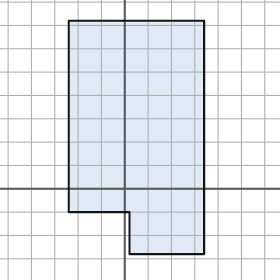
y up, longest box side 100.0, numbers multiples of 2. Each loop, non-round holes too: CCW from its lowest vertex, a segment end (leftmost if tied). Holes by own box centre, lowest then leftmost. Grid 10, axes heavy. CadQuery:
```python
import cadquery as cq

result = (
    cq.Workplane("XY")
    .moveTo(2.0, -28.0)
    .lineTo(34.0, -28.0)
    .lineTo(34.0, 72.0)
    .lineTo(-24.0, 72.0)
    .lineTo(-24.0, -10.0)
    .lineTo(2.0, -10.0)
    .close()
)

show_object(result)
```